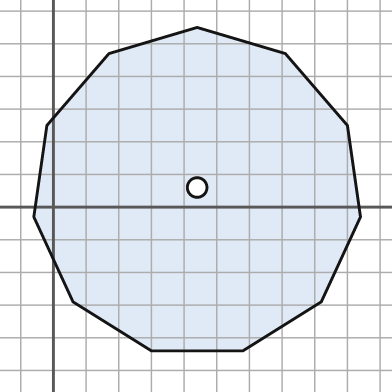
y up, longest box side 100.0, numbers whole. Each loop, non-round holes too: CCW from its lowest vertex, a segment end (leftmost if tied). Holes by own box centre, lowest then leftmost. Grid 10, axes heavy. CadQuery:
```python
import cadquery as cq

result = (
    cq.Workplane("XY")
    .moveTo(30.0, -44.0)
    .lineTo(58.0, -44.0)
    .lineTo(82.0, -29.0)
    .lineTo(94.0, -3.0)
    .lineTo(90.0, 25.0)
    .lineTo(71.0, 47.0)
    .lineTo(44.0, 55.0)
    .lineTo(17.0, 47.0)
    .lineTo(-2.0, 25.0)
    .lineTo(-6.0, -3.0)
    .lineTo(6.0, -29.0)
    .close()
    .moveTo(44.0, 6.0)
    .circle(3.0)
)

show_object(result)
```